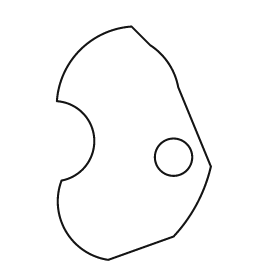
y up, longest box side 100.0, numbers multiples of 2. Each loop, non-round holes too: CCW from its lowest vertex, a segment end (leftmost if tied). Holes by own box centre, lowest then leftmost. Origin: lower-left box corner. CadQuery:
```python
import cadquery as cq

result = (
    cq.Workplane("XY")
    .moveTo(22.0, 0.0)
    .lineTo(50.0, 10.0)
    .threePointArc((60.0, 24.0), (66.0, 40.0))
    .lineTo(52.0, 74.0)
    .threePointArc((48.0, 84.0), (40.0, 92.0))
    .lineTo(32.0, 100.0)
    .threePointArc((10.0, 90.0), (0.0, 68.0))
    .threePointArc((16.0, 52.0), (2.0, 34.0))
    .threePointArc((4.0, 12.0), (22.0, 0.0))
    .close()
    .moveTo(50.0, 44.0)
    .circle(8.0)
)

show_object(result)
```